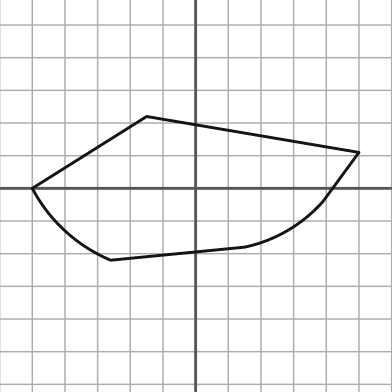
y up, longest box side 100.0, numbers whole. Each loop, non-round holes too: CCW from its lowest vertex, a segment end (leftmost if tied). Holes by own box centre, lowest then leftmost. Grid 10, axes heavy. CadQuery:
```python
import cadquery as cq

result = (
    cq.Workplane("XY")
    .moveTo(-26.0, -22.0)
    .lineTo(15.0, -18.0)
    .threePointArc((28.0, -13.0), (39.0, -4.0))
    .lineTo(50.0, 11.0)
    .lineTo(-15.0, 22.0)
    .lineTo(-50.0, 0.0)
    .threePointArc((-40.0, -13.0), (-26.0, -22.0))
    .close()
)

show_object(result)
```